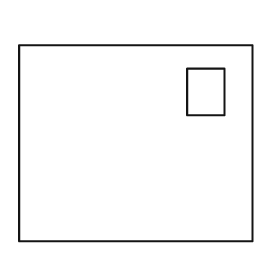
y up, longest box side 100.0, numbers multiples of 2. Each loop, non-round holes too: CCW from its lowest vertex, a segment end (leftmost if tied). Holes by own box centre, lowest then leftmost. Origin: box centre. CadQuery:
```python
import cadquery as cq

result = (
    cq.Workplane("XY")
    .moveTo(-50.0, -42.0)
    .lineTo(50.0, -42.0)
    .lineTo(50.0, 42.0)
    .lineTo(-50.0, 42.0)
    .close()
    .moveTo(22.0, 12.0)
    .lineTo(38.0, 12.0)
    .lineTo(38.0, 32.0)
    .lineTo(22.0, 32.0)
    .close()
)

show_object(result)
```